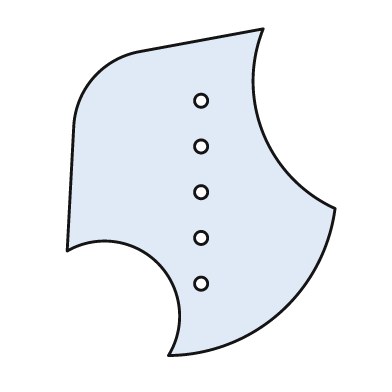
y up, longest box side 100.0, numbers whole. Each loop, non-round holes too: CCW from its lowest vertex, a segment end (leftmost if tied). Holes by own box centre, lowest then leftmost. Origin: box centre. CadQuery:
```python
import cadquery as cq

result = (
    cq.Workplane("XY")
    .moveTo(-10.0, -50.0)
    .threePointArc((24.0, -37.0), (41.0, -5.0))
    .threePointArc((19.0, 18.0), (19.0, 50.0))
    .lineTo(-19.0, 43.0)
    .threePointArc((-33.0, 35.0), (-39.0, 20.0))
    .lineTo(-41.0, -18.0)
    .threePointArc((-13.0, -22.0), (-10.0, -50.0))
    .close()
    .moveTo(0.0, -28.0)
    .circle(2.0)
    .moveTo(0.0, -14.0)
    .circle(2.0)
    .moveTo(0.0, 0.0)
    .circle(2.0)
    .moveTo(0.0, 14.0)
    .circle(2.0)
    .moveTo(0.0, 28.0)
    .circle(2.0)
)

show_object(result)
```